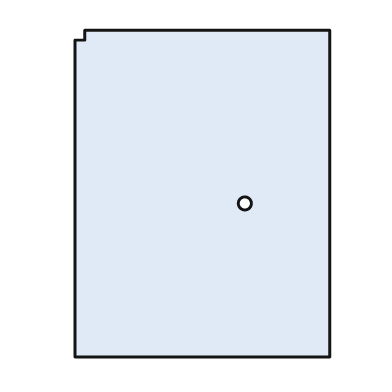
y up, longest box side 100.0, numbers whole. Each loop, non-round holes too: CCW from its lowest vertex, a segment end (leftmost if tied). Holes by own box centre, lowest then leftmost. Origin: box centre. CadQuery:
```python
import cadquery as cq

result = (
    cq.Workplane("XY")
    .moveTo(-39.0, -50.0)
    .lineTo(39.0, -50.0)
    .lineTo(39.0, 50.0)
    .lineTo(-36.0, 50.0)
    .lineTo(-36.0, 47.0)
    .lineTo(-39.0, 47.0)
    .close()
    .moveTo(13.0, -3.0)
    .circle(2.0)
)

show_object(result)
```